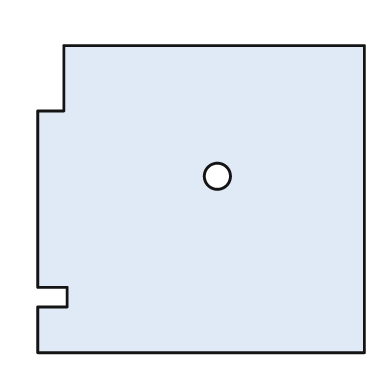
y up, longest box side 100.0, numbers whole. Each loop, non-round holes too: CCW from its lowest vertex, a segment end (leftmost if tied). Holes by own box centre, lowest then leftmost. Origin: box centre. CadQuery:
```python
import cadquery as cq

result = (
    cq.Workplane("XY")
    .moveTo(-50.0, -47.0)
    .lineTo(50.0, -47.0)
    .lineTo(50.0, 47.0)
    .lineTo(-42.0, 47.0)
    .lineTo(-42.0, 27.0)
    .lineTo(-50.0, 27.0)
    .lineTo(-50.0, -27.0)
    .lineTo(-41.0, -27.0)
    .lineTo(-41.0, -33.0)
    .lineTo(-50.0, -33.0)
    .close()
    .moveTo(5.0, 7.0)
    .circle(4.0)
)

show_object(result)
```